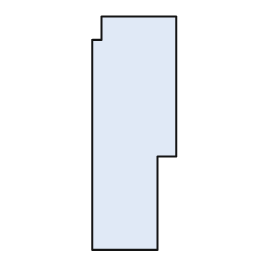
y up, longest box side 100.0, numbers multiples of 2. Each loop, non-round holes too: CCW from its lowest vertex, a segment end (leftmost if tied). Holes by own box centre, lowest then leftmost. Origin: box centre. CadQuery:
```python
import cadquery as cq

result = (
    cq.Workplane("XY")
    .moveTo(-18.0, -50.0)
    .lineTo(10.0, -50.0)
    .lineTo(10.0, -10.0)
    .lineTo(18.0, -10.0)
    .lineTo(18.0, 50.0)
    .lineTo(-14.0, 50.0)
    .lineTo(-14.0, 40.0)
    .lineTo(-18.0, 40.0)
    .close()
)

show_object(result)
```